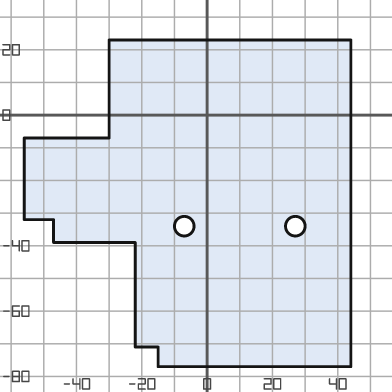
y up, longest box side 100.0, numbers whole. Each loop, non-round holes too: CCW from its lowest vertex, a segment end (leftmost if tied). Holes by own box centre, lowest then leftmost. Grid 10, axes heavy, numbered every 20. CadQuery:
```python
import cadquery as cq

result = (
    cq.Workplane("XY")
    .moveTo(-15.0, -77.0)
    .lineTo(44.0, -77.0)
    .lineTo(44.0, 23.0)
    .lineTo(-30.0, 23.0)
    .lineTo(-30.0, -7.0)
    .lineTo(-56.0, -7.0)
    .lineTo(-56.0, -32.0)
    .lineTo(-47.0, -32.0)
    .lineTo(-47.0, -39.0)
    .lineTo(-22.0, -39.0)
    .lineTo(-22.0, -71.0)
    .lineTo(-15.0, -71.0)
    .close()
    .moveTo(-7.0, -34.0)
    .circle(3.0)
    .moveTo(27.0, -34.0)
    .circle(3.0)
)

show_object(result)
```